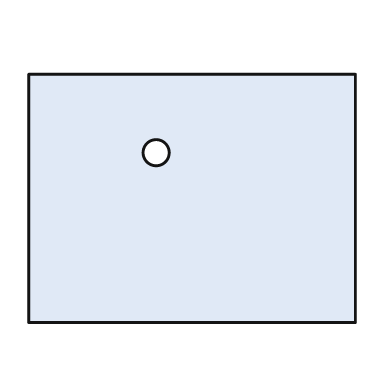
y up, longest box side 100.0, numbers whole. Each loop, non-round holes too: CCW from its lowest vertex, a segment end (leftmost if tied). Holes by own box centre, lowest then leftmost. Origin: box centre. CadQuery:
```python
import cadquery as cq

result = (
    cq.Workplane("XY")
    .moveTo(-50.0, -38.0)
    .lineTo(50.0, -38.0)
    .lineTo(50.0, 38.0)
    .lineTo(-50.0, 38.0)
    .close()
    .moveTo(-11.0, 14.0)
    .circle(4.0)
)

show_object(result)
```